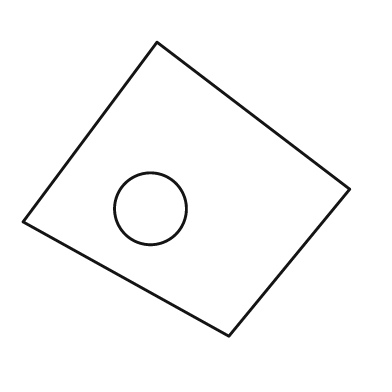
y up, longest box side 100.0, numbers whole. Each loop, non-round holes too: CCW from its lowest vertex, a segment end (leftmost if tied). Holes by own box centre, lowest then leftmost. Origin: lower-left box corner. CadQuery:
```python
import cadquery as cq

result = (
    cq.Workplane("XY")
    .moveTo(63.0, 0.0)
    .lineTo(100.0, 45.0)
    .lineTo(41.0, 90.0)
    .lineTo(0.0, 35.0)
    .close()
    .moveTo(39.0, 39.0)
    .circle(11.0)
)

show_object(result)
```